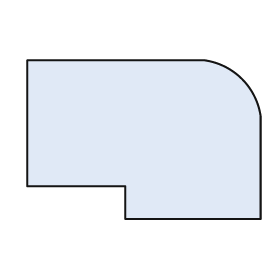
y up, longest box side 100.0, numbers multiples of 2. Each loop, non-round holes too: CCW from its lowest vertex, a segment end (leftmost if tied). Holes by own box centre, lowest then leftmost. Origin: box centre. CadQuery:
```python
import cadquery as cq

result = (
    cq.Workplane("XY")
    .moveTo(-8.0, -34.0)
    .lineTo(50.0, -34.0)
    .lineTo(50.0, 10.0)
    .threePointArc((42.0, 26.0), (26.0, 34.0))
    .lineTo(-50.0, 34.0)
    .lineTo(-50.0, -20.0)
    .lineTo(-8.0, -20.0)
    .close()
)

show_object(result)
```